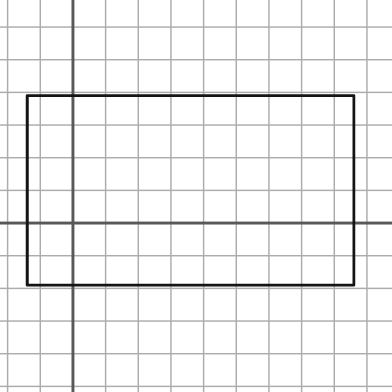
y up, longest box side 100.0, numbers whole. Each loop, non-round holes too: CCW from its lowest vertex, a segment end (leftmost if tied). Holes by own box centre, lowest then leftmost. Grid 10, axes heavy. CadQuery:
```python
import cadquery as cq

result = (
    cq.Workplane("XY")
    .moveTo(-14.0, -19.0)
    .lineTo(86.0, -19.0)
    .lineTo(86.0, 39.0)
    .lineTo(-14.0, 39.0)
    .close()
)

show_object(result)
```